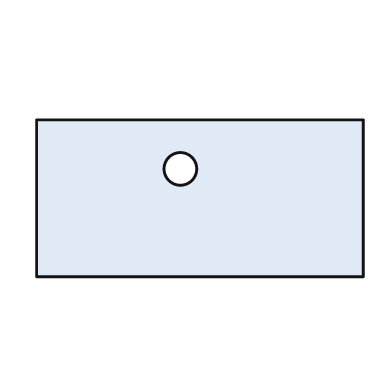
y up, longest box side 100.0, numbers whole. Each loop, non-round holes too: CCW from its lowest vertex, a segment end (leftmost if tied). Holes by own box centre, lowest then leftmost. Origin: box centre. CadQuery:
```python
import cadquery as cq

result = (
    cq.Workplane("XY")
    .moveTo(-50.0, -24.0)
    .lineTo(50.0, -24.0)
    .lineTo(50.0, 24.0)
    .lineTo(-50.0, 24.0)
    .close()
    .moveTo(-6.0, 9.0)
    .circle(5.0)
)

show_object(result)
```